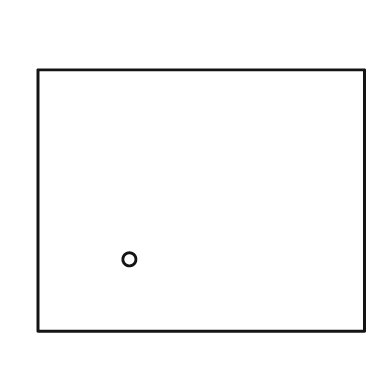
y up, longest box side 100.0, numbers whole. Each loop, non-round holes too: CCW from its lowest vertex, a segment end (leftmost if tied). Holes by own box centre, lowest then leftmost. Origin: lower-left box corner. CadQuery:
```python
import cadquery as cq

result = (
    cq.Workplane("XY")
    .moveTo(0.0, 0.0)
    .lineTo(100.0, 0.0)
    .lineTo(100.0, 80.0)
    .lineTo(0.0, 80.0)
    .close()
    .moveTo(28.0, 22.0)
    .circle(2.0)
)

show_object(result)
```